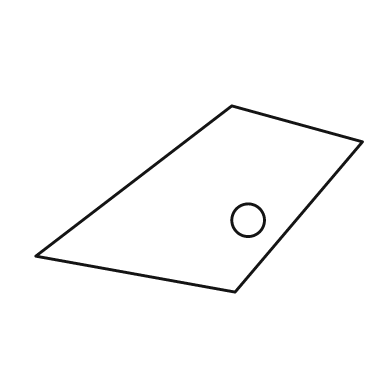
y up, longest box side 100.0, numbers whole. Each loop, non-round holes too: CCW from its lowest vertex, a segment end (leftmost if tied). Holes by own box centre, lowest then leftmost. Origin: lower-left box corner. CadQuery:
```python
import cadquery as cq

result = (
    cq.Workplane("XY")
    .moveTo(61.0, 0.0)
    .lineTo(100.0, 46.0)
    .lineTo(60.0, 57.0)
    .lineTo(0.0, 11.0)
    .close()
    .moveTo(65.0, 22.0)
    .circle(5.0)
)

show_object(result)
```